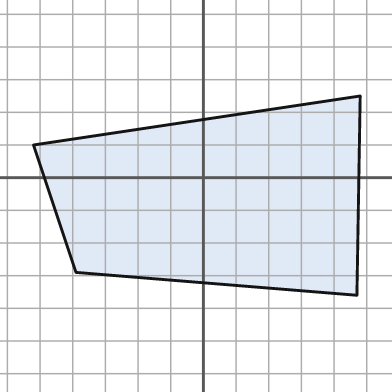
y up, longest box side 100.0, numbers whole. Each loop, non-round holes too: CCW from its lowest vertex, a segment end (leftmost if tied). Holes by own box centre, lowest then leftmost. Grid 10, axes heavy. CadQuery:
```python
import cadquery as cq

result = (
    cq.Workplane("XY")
    .moveTo(47.0, -36.0)
    .lineTo(48.0, 25.0)
    .lineTo(-52.0, 10.0)
    .lineTo(-39.0, -29.0)
    .close()
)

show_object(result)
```